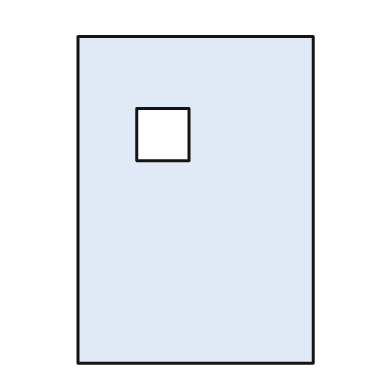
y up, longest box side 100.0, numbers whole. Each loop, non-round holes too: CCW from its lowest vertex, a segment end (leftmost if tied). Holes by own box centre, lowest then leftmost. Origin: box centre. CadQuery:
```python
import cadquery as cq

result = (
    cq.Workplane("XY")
    .moveTo(-36.0, -50.0)
    .lineTo(36.0, -50.0)
    .lineTo(36.0, 50.0)
    .lineTo(-36.0, 50.0)
    .close()
    .moveTo(-18.0, 12.0)
    .lineTo(-2.0, 12.0)
    .lineTo(-2.0, 28.0)
    .lineTo(-18.0, 28.0)
    .close()
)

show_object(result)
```